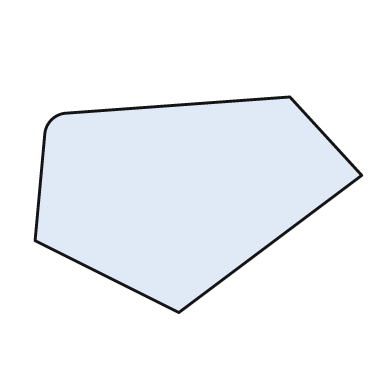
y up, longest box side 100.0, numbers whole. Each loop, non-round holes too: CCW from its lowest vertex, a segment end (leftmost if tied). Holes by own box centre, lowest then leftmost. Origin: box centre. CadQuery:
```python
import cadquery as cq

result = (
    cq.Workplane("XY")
    .moveTo(-6.0, -33.0)
    .lineTo(50.0, 9.0)
    .lineTo(28.0, 33.0)
    .lineTo(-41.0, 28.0)
    .threePointArc((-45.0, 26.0), (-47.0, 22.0))
    .lineTo(-50.0, -11.0)
    .close()
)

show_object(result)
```